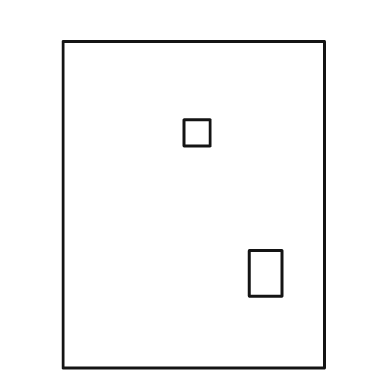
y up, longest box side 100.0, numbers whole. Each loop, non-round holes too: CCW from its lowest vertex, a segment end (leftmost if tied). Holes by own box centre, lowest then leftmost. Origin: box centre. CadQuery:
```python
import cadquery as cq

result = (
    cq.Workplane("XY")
    .moveTo(-40.0, -50.0)
    .lineTo(40.0, -50.0)
    .lineTo(40.0, 50.0)
    .lineTo(-40.0, 50.0)
    .close()
    .moveTo(17.0, -28.0)
    .lineTo(27.0, -28.0)
    .lineTo(27.0, -14.0)
    .lineTo(17.0, -14.0)
    .close()
    .moveTo(-3.0, 18.0)
    .lineTo(5.0, 18.0)
    .lineTo(5.0, 26.0)
    .lineTo(-3.0, 26.0)
    .close()
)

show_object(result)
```